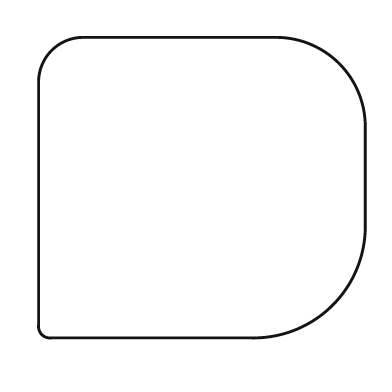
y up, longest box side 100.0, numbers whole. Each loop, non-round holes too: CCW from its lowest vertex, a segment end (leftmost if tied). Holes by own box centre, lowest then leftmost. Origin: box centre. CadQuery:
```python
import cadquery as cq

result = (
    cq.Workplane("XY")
    .moveTo(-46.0, -46.0)
    .lineTo(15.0, -46.0)
    .threePointArc((40.0, -36.0), (50.0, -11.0))
    .lineTo(50.0, 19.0)
    .threePointArc((42.0, 38.0), (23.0, 46.0))
    .lineTo(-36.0, 46.0)
    .threePointArc((-46.0, 42.0), (-50.0, 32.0))
    .lineTo(-50.0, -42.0)
    .threePointArc((-49.0, -45.0), (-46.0, -46.0))
    .close()
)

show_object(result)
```